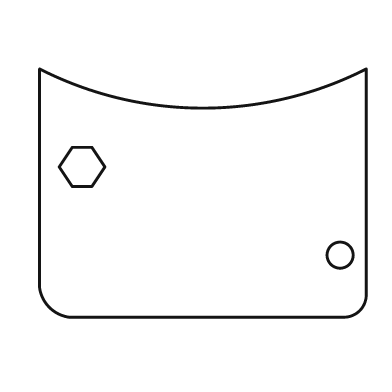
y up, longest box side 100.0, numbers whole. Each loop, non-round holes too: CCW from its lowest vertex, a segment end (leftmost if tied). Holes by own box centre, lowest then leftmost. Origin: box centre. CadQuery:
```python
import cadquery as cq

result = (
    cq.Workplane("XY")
    .moveTo(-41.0, -38.0)
    .lineTo(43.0, -38.0)
    .threePointArc((48.0, -36.0), (50.0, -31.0))
    .lineTo(50.0, 38.0)
    .threePointArc((0.0, 26.0), (-50.0, 38.0))
    .lineTo(-50.0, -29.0)
    .threePointArc((-47.0, -35.0), (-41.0, -38.0))
    .close()
    .moveTo(42.0, -19.0)
    .circle(4.0)
    .moveTo(-40.0, 2.0)
    .lineTo(-34.0, 2.0)
    .lineTo(-30.0, 8.0)
    .lineTo(-34.0, 14.0)
    .lineTo(-40.0, 14.0)
    .lineTo(-44.0, 8.0)
    .close()
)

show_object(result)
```